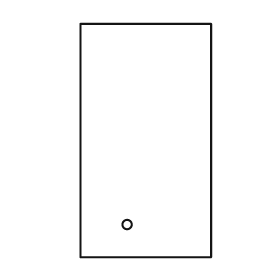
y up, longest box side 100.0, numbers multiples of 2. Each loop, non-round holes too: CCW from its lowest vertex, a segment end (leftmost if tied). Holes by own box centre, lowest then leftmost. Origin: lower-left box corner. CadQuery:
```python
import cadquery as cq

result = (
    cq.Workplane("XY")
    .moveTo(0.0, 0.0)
    .lineTo(56.0, 0.0)
    .lineTo(56.0, 100.0)
    .lineTo(0.0, 100.0)
    .close()
    .moveTo(20.0, 14.0)
    .circle(2.0)
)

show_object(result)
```